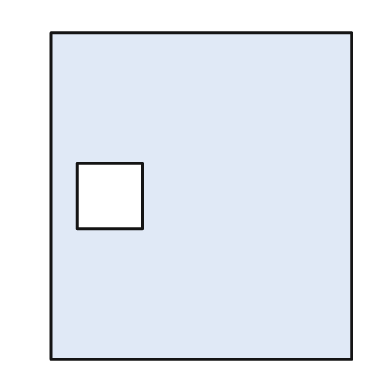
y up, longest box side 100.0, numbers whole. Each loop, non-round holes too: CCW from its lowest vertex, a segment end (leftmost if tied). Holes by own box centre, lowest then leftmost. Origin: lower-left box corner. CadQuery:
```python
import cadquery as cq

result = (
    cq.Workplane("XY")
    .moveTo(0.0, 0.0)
    .lineTo(92.0, 0.0)
    .lineTo(92.0, 100.0)
    .lineTo(0.0, 100.0)
    .close()
    .moveTo(8.0, 40.0)
    .lineTo(28.0, 40.0)
    .lineTo(28.0, 60.0)
    .lineTo(8.0, 60.0)
    .close()
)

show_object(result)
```